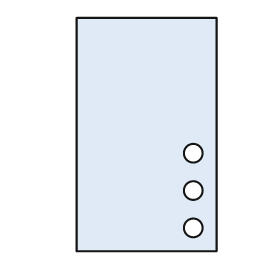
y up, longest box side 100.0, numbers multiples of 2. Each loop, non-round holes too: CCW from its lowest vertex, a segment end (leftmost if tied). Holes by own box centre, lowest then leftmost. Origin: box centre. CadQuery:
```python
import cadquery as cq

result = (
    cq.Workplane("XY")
    .moveTo(-30.0, -50.0)
    .lineTo(30.0, -50.0)
    .lineTo(30.0, 50.0)
    .lineTo(-30.0, 50.0)
    .close()
    .moveTo(20.0, -40.0)
    .circle(4.0)
    .moveTo(20.0, -24.0)
    .circle(4.0)
    .moveTo(20.0, -8.0)
    .circle(4.0)
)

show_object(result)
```